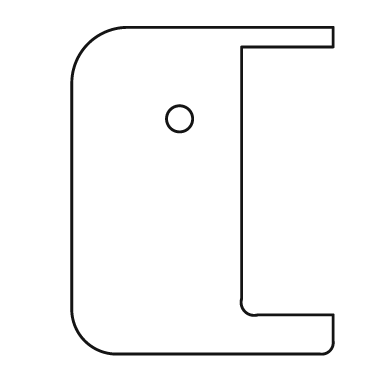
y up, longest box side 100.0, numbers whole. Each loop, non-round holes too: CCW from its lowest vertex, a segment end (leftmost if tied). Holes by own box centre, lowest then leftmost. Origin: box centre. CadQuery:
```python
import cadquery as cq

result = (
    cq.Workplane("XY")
    .moveTo(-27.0, -50.0)
    .lineTo(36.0, -50.0)
    .threePointArc((39.0, -49.0), (40.0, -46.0))
    .lineTo(40.0, -38.0)
    .lineTo(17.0, -38.0)
    .threePointArc((13.0, -37.0), (12.0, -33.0))
    .lineTo(12.0, 44.0)
    .lineTo(40.0, 44.0)
    .lineTo(40.0, 50.0)
    .lineTo(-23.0, 50.0)
    .threePointArc((-35.0, 45.0), (-40.0, 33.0))
    .lineTo(-40.0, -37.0)
    .threePointArc((-36.0, -46.0), (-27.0, -50.0))
    .close()
    .moveTo(-7.0, 22.0)
    .circle(4.0)
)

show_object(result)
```